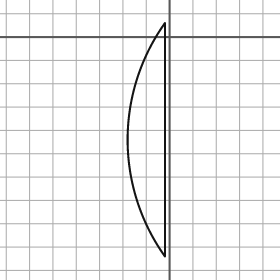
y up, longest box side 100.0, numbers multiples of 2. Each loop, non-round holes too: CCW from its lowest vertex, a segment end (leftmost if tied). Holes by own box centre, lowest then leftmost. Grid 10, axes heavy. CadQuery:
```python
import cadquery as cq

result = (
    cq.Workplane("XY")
    .moveTo(-2.0, -94.0)
    .lineTo(-2.0, 6.0)
    .threePointArc((-18.0, -44.0), (-2.0, -94.0))
    .close()
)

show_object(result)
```